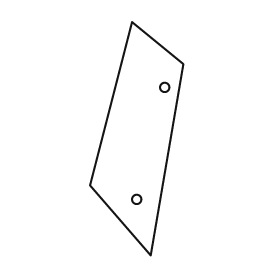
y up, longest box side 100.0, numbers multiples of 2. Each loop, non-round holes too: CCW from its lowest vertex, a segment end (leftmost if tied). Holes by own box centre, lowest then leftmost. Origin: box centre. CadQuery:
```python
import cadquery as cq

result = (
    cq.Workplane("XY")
    .moveTo(6.0, -50.0)
    .lineTo(20.0, 32.0)
    .lineTo(-2.0, 50.0)
    .lineTo(-20.0, -20.0)
    .close()
    .moveTo(0.0, -26.0)
    .circle(2.0)
    .moveTo(12.0, 22.0)
    .circle(2.0)
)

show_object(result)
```